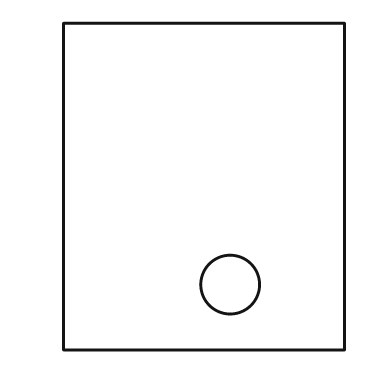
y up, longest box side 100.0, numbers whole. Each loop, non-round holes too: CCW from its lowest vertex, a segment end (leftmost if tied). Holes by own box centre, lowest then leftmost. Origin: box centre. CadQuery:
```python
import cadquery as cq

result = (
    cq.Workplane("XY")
    .moveTo(-43.0, -50.0)
    .lineTo(43.0, -50.0)
    .lineTo(43.0, 50.0)
    .lineTo(-43.0, 50.0)
    .close()
    .moveTo(8.0, -30.0)
    .circle(9.0)
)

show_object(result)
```